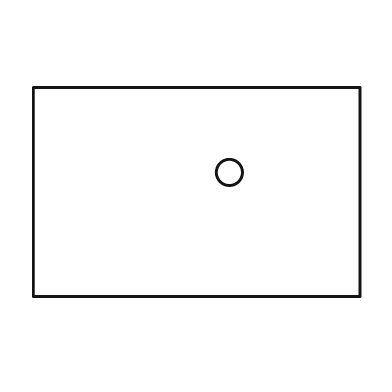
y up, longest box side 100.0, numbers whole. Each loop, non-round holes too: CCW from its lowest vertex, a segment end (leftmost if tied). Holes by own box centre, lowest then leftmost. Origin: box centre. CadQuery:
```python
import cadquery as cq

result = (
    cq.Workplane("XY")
    .moveTo(-50.0, -32.0)
    .lineTo(50.0, -32.0)
    .lineTo(50.0, 32.0)
    .lineTo(-50.0, 32.0)
    .close()
    .moveTo(10.0, 6.0)
    .circle(4.0)
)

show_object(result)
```